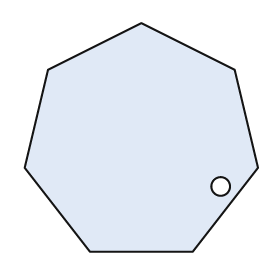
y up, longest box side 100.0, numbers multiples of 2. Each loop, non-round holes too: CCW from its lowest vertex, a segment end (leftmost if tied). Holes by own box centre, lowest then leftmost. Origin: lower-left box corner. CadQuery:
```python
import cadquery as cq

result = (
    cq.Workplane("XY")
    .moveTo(28.0, 0.0)
    .lineTo(72.0, 0.0)
    .lineTo(100.0, 36.0)
    .lineTo(90.0, 78.0)
    .lineTo(50.0, 98.0)
    .lineTo(10.0, 78.0)
    .lineTo(0.0, 36.0)
    .close()
    .moveTo(84.0, 28.0)
    .circle(4.0)
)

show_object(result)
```